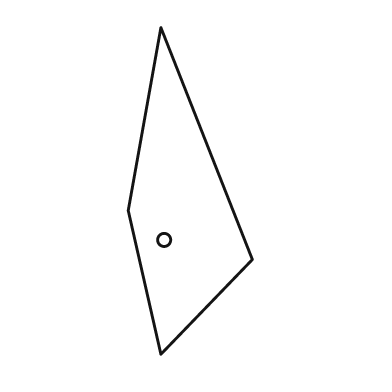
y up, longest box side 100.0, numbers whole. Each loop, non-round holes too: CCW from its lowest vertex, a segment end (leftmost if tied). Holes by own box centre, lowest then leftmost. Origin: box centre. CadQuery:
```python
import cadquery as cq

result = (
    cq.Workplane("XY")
    .moveTo(-9.0, -50.0)
    .lineTo(19.0, -21.0)
    .lineTo(-9.0, 50.0)
    .lineTo(-19.0, -6.0)
    .close()
    .moveTo(-8.0, -15.0)
    .circle(2.0)
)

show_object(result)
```